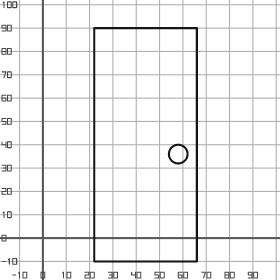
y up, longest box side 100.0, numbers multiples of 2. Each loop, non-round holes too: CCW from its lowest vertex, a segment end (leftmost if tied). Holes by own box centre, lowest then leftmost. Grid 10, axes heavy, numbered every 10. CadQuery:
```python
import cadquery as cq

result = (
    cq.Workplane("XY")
    .moveTo(22.0, -10.0)
    .lineTo(66.0, -10.0)
    .lineTo(66.0, 90.0)
    .lineTo(22.0, 90.0)
    .close()
    .moveTo(58.0, 36.0)
    .circle(4.0)
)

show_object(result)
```